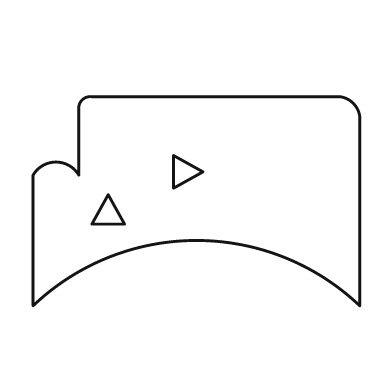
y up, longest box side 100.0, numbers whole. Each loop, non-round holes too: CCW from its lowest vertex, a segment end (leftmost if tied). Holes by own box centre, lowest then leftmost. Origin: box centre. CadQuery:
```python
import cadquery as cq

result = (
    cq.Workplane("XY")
    .moveTo(-50.0, -32.0)
    .threePointArc((0.0, -12.0), (50.0, -32.0))
    .lineTo(50.0, 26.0)
    .threePointArc((48.0, 30.0), (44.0, 32.0))
    .lineTo(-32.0, 32.0)
    .threePointArc((-35.0, 31.0), (-36.0, 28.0))
    .lineTo(-36.0, 8.0)
    .threePointArc((-43.0, 12.0), (-50.0, 8.0))
    .close()
    .moveTo(-32.0, -7.0)
    .lineTo(-22.0, -7.0)
    .lineTo(-27.0, 2.0)
    .close()
    .moveTo(-7.0, 4.0)
    .lineTo(2.0, 9.0)
    .lineTo(-7.0, 14.0)
    .close()
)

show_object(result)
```